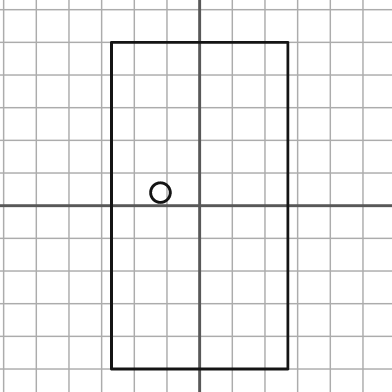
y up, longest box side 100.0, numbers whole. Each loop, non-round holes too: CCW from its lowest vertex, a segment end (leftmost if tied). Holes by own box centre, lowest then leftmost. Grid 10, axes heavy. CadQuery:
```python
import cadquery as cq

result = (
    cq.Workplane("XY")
    .moveTo(-27.0, -50.0)
    .lineTo(27.0, -50.0)
    .lineTo(27.0, 50.0)
    .lineTo(-27.0, 50.0)
    .close()
    .moveTo(-12.0, 4.0)
    .circle(3.0)
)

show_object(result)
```